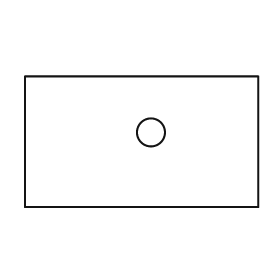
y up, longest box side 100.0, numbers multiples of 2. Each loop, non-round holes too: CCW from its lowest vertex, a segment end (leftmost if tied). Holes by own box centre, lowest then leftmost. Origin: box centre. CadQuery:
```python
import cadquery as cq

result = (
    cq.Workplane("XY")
    .moveTo(-50.0, -28.0)
    .lineTo(50.0, -28.0)
    .lineTo(50.0, 28.0)
    .lineTo(-50.0, 28.0)
    .close()
    .moveTo(4.0, 4.0)
    .circle(6.0)
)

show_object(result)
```